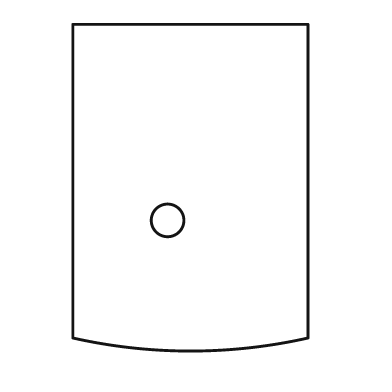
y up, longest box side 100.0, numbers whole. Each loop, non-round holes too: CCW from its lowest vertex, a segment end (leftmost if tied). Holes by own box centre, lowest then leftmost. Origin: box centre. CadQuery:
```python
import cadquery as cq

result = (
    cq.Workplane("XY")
    .moveTo(-36.0, -46.0)
    .threePointArc((0.0, -50.0), (36.0, -46.0))
    .lineTo(36.0, 50.0)
    .lineTo(-36.0, 50.0)
    .close()
    .moveTo(-7.0, -10.0)
    .circle(5.0)
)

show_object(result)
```